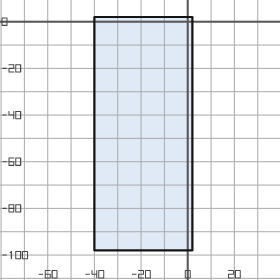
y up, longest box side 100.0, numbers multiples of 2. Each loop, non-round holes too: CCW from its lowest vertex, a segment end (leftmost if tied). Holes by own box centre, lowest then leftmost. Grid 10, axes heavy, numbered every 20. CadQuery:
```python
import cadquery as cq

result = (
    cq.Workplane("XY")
    .moveTo(-40.0, -98.0)
    .lineTo(2.0, -98.0)
    .lineTo(2.0, 2.0)
    .lineTo(-40.0, 2.0)
    .close()
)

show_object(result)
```